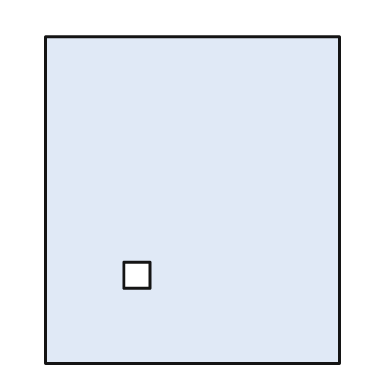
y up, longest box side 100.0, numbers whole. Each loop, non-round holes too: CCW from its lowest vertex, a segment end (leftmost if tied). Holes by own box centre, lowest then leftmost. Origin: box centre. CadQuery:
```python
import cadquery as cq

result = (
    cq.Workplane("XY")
    .moveTo(-45.0, -50.0)
    .lineTo(45.0, -50.0)
    .lineTo(45.0, 50.0)
    .lineTo(-45.0, 50.0)
    .close()
    .moveTo(-21.0, -27.0)
    .lineTo(-13.0, -27.0)
    .lineTo(-13.0, -19.0)
    .lineTo(-21.0, -19.0)
    .close()
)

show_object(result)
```